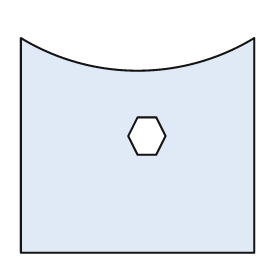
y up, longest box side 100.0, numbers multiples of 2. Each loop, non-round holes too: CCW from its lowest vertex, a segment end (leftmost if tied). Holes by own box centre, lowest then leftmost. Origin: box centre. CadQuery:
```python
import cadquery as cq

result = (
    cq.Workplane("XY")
    .moveTo(-50.0, -46.0)
    .lineTo(50.0, -46.0)
    .lineTo(50.0, 46.0)
    .threePointArc((0.0, 32.0), (-50.0, 46.0))
    .close()
    .moveTo(0.0, -4.0)
    .lineTo(8.0, -4.0)
    .lineTo(12.0, 4.0)
    .lineTo(8.0, 12.0)
    .lineTo(0.0, 12.0)
    .lineTo(-4.0, 4.0)
    .close()
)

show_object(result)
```